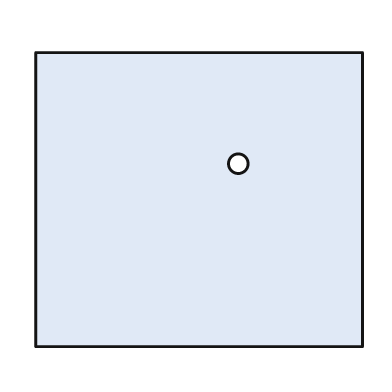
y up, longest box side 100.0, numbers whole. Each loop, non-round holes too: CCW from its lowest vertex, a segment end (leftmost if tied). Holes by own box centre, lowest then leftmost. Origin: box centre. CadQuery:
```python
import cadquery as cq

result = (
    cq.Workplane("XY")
    .moveTo(-50.0, -45.0)
    .lineTo(50.0, -45.0)
    .lineTo(50.0, 45.0)
    .lineTo(-50.0, 45.0)
    .close()
    .moveTo(12.0, 11.0)
    .circle(3.0)
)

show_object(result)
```